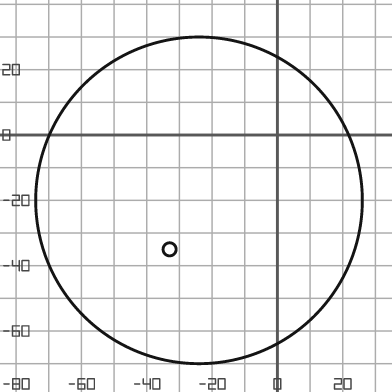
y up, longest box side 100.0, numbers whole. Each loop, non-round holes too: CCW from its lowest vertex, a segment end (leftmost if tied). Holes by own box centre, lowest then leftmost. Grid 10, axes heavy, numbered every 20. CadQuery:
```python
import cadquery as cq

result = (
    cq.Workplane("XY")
    .moveTo(-24.0, -20.0)
    .circle(50.0)
    .moveTo(-33.0, -35.0)
    .circle(2.0)
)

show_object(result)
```